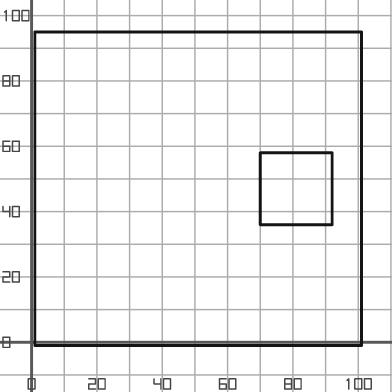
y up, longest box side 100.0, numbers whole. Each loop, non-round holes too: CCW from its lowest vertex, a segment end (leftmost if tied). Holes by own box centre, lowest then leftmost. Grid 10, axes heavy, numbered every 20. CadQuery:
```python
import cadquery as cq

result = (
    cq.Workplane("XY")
    .moveTo(1.0, -1.0)
    .lineTo(101.0, -1.0)
    .lineTo(101.0, 95.0)
    .lineTo(1.0, 95.0)
    .close()
    .moveTo(70.0, 36.0)
    .lineTo(92.0, 36.0)
    .lineTo(92.0, 58.0)
    .lineTo(70.0, 58.0)
    .close()
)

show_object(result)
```